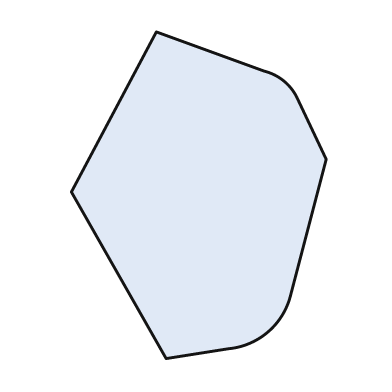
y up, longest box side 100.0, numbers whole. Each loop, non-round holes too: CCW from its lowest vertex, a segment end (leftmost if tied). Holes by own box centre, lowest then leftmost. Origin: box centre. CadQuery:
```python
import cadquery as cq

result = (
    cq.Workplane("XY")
    .moveTo(-10.0, -50.0)
    .lineTo(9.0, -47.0)
    .threePointArc((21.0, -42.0), (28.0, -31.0))
    .lineTo(39.0, 11.0)
    .lineTo(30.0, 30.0)
    .threePointArc((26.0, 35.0), (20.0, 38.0))
    .lineTo(-13.0, 50.0)
    .lineTo(-39.0, 1.0)
    .close()
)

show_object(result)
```